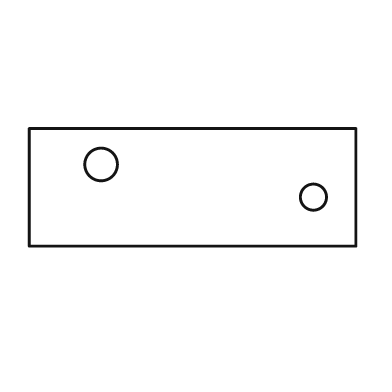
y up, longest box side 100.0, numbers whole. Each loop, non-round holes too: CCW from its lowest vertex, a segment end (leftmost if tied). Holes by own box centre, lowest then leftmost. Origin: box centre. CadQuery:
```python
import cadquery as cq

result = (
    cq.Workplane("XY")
    .moveTo(-50.0, -18.0)
    .lineTo(50.0, -18.0)
    .lineTo(50.0, 18.0)
    .lineTo(-50.0, 18.0)
    .close()
    .moveTo(37.0, -3.0)
    .circle(4.0)
    .moveTo(-28.0, 7.0)
    .circle(5.0)
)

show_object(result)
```